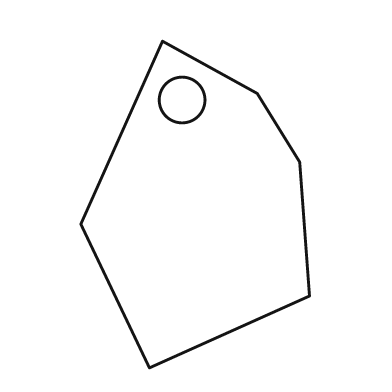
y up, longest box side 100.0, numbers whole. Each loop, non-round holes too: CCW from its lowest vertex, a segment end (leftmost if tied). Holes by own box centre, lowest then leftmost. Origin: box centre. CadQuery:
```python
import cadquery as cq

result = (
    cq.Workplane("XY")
    .moveTo(-14.0, -50.0)
    .lineTo(35.0, -28.0)
    .lineTo(32.0, 13.0)
    .lineTo(19.0, 34.0)
    .lineTo(-10.0, 50.0)
    .lineTo(-35.0, -6.0)
    .close()
    .moveTo(-4.0, 32.0)
    .circle(7.0)
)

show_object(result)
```